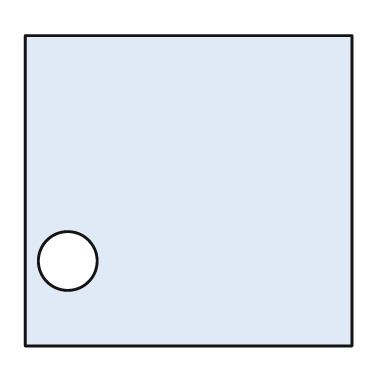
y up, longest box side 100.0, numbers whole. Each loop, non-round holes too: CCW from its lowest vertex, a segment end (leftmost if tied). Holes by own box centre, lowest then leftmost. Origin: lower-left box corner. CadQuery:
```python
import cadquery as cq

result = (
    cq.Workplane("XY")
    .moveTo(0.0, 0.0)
    .lineTo(100.0, 0.0)
    .lineTo(100.0, 95.0)
    .lineTo(0.0, 95.0)
    .close()
    .moveTo(13.0, 26.0)
    .circle(9.0)
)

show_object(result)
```